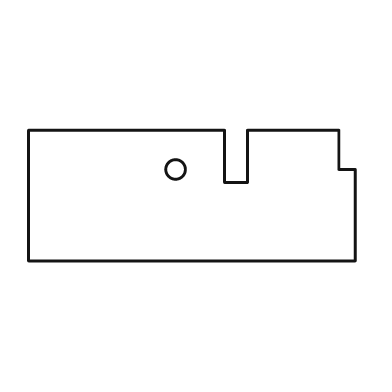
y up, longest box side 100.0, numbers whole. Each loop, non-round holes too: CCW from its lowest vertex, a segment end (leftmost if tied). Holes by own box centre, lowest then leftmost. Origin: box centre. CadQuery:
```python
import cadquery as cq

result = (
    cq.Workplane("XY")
    .moveTo(-50.0, -20.0)
    .lineTo(50.0, -20.0)
    .lineTo(50.0, 8.0)
    .lineTo(45.0, 8.0)
    .lineTo(45.0, 20.0)
    .lineTo(17.0, 20.0)
    .lineTo(17.0, 4.0)
    .lineTo(10.0, 4.0)
    .lineTo(10.0, 20.0)
    .lineTo(-50.0, 20.0)
    .close()
    .moveTo(-5.0, 8.0)
    .circle(3.0)
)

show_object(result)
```